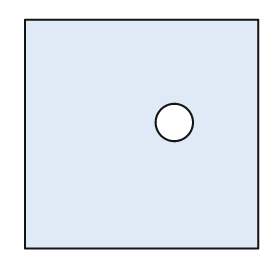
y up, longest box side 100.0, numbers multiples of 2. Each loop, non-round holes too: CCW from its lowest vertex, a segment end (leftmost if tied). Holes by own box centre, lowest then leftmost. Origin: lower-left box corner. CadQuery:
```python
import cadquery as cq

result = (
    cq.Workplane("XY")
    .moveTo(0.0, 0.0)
    .lineTo(100.0, 0.0)
    .lineTo(100.0, 98.0)
    .lineTo(0.0, 98.0)
    .close()
    .moveTo(64.0, 54.0)
    .circle(8.0)
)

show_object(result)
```